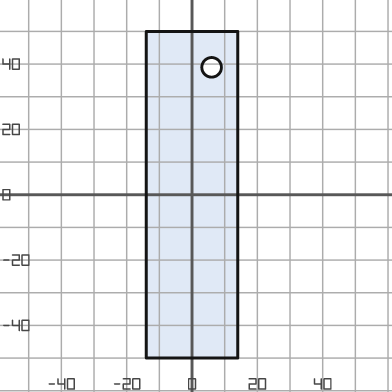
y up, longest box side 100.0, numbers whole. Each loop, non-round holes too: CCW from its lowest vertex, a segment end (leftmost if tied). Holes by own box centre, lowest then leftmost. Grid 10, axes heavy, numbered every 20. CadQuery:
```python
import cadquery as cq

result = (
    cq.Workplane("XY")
    .moveTo(-14.0, -50.0)
    .lineTo(14.0, -50.0)
    .lineTo(14.0, 50.0)
    .lineTo(-14.0, 50.0)
    .close()
    .moveTo(6.0, 39.0)
    .circle(3.0)
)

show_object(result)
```